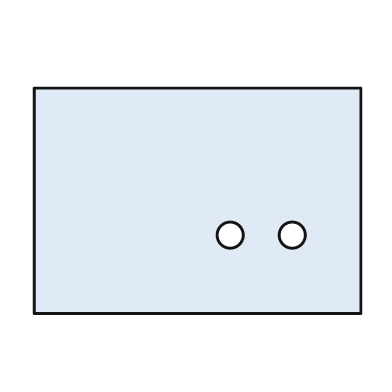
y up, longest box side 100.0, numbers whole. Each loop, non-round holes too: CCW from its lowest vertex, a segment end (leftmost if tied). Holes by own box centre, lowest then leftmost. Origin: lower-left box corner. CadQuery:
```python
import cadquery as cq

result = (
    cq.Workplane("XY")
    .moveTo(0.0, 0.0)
    .lineTo(100.0, 0.0)
    .lineTo(100.0, 69.0)
    .lineTo(0.0, 69.0)
    .close()
    .moveTo(60.0, 24.0)
    .circle(4.0)
    .moveTo(79.0, 24.0)
    .circle(4.0)
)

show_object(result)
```